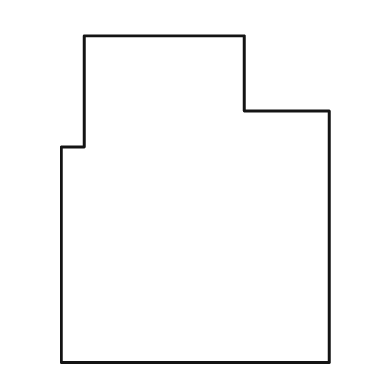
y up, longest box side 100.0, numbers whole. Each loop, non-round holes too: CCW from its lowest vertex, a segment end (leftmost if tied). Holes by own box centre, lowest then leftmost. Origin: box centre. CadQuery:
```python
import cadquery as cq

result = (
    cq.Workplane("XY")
    .moveTo(-41.0, -50.0)
    .lineTo(41.0, -50.0)
    .lineTo(41.0, 27.0)
    .lineTo(15.0, 27.0)
    .lineTo(15.0, 50.0)
    .lineTo(-34.0, 50.0)
    .lineTo(-34.0, 16.0)
    .lineTo(-41.0, 16.0)
    .close()
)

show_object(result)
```